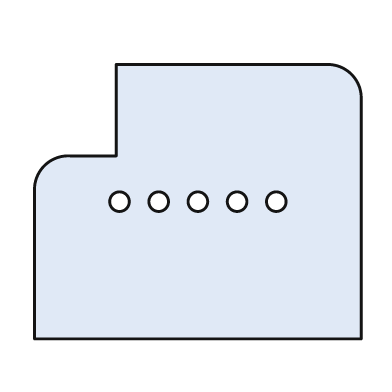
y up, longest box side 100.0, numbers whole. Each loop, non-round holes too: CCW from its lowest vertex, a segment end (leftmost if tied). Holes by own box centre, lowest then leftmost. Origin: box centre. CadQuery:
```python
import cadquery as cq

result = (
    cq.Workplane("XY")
    .moveTo(-50.0, -42.0)
    .lineTo(50.0, -42.0)
    .lineTo(50.0, 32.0)
    .threePointArc((47.0, 39.0), (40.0, 42.0))
    .lineTo(-25.0, 42.0)
    .lineTo(-25.0, 14.0)
    .lineTo(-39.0, 14.0)
    .threePointArc((-47.0, 11.0), (-50.0, 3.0))
    .close()
    .moveTo(-24.0, 0.0)
    .circle(3.0)
    .moveTo(-12.0, 0.0)
    .circle(3.0)
    .moveTo(0.0, 0.0)
    .circle(3.0)
    .moveTo(12.0, 0.0)
    .circle(3.0)
    .moveTo(24.0, 0.0)
    .circle(3.0)
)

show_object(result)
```